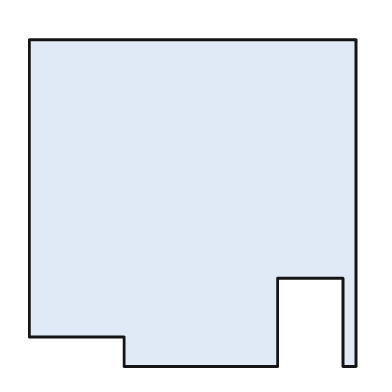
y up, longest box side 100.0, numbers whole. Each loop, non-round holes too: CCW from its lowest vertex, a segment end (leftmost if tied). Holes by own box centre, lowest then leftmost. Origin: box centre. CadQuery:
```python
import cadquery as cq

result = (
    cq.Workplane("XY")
    .moveTo(-21.0, -50.0)
    .lineTo(26.0, -50.0)
    .lineTo(26.0, -23.0)
    .lineTo(46.0, -23.0)
    .lineTo(46.0, -50.0)
    .lineTo(50.0, -50.0)
    .lineTo(50.0, 50.0)
    .lineTo(-50.0, 50.0)
    .lineTo(-50.0, -41.0)
    .lineTo(-21.0, -41.0)
    .close()
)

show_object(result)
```